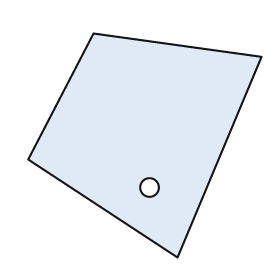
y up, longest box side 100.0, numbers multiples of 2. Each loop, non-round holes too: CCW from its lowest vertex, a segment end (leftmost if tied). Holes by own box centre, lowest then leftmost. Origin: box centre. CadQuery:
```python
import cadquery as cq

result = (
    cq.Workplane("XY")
    .moveTo(14.0, -48.0)
    .lineTo(50.0, 38.0)
    .lineTo(-22.0, 48.0)
    .lineTo(-50.0, -6.0)
    .close()
    .moveTo(2.0, -18.0)
    .circle(4.0)
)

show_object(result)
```